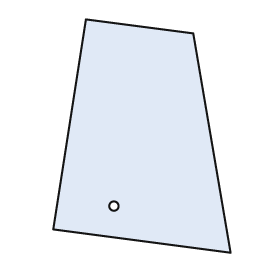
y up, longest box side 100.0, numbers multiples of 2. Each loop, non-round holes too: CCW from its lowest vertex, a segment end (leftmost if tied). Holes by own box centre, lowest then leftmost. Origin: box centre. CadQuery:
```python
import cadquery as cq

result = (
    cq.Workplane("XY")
    .moveTo(38.0, -50.0)
    .lineTo(22.0, 44.0)
    .lineTo(-24.0, 50.0)
    .lineTo(-38.0, -40.0)
    .close()
    .moveTo(-12.0, -30.0)
    .circle(2.0)
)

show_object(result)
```